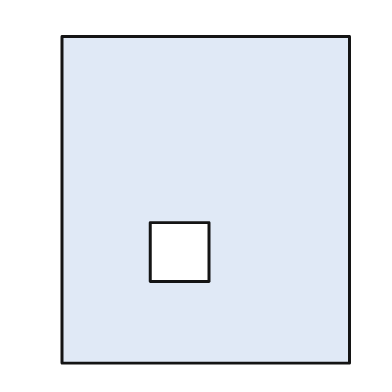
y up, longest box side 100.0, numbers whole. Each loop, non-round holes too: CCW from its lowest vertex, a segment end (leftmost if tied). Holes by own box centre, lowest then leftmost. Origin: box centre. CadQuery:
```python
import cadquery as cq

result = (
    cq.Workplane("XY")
    .moveTo(-44.0, -50.0)
    .lineTo(44.0, -50.0)
    .lineTo(44.0, 50.0)
    .lineTo(-44.0, 50.0)
    .close()
    .moveTo(-17.0, -25.0)
    .lineTo(1.0, -25.0)
    .lineTo(1.0, -7.0)
    .lineTo(-17.0, -7.0)
    .close()
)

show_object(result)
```